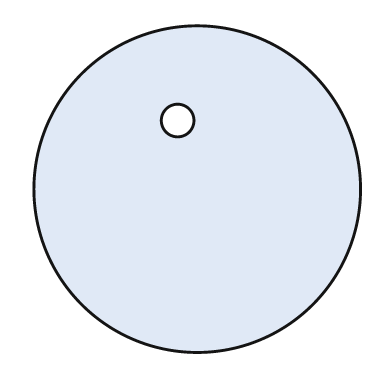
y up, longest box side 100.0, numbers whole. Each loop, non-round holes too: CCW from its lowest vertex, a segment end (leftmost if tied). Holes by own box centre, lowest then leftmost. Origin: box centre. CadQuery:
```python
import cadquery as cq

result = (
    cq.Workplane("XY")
    .moveTo(0.0, 0.0)
    .circle(50.0)
    .moveTo(-6.0, 21.0)
    .circle(5.0)
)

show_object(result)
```